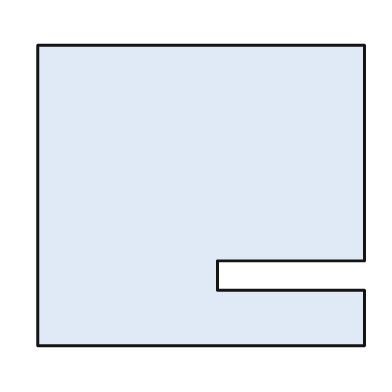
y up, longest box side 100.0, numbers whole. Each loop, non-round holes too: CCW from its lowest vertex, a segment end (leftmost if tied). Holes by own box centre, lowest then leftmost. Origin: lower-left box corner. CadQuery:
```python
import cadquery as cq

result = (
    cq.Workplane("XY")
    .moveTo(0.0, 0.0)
    .lineTo(100.0, 0.0)
    .lineTo(100.0, 17.0)
    .lineTo(55.0, 17.0)
    .lineTo(55.0, 26.0)
    .lineTo(100.0, 26.0)
    .lineTo(100.0, 92.0)
    .lineTo(0.0, 92.0)
    .close()
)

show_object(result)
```